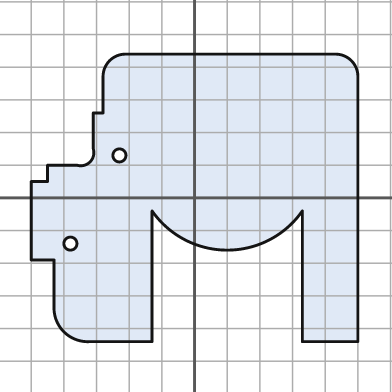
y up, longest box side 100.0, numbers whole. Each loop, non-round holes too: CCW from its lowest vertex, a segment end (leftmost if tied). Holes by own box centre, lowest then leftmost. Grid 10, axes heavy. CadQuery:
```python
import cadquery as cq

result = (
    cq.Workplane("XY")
    .moveTo(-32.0, -44.0)
    .lineTo(-13.0, -44.0)
    .lineTo(-13.0, -4.0)
    .threePointArc((10.0, -16.0), (33.0, -4.0))
    .lineTo(33.0, -44.0)
    .lineTo(50.0, -44.0)
    .lineTo(50.0, 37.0)
    .threePointArc((48.0, 42.0), (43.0, 44.0))
    .lineTo(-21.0, 44.0)
    .threePointArc((-26.0, 42.0), (-28.0, 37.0))
    .lineTo(-28.0, 26.0)
    .lineTo(-31.0, 26.0)
    .lineTo(-31.0, 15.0)
    .threePointArc((-32.0, 11.0), (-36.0, 10.0))
    .lineTo(-45.0, 10.0)
    .lineTo(-45.0, 5.0)
    .lineTo(-50.0, 5.0)
    .lineTo(-50.0, -19.0)
    .lineTo(-43.0, -19.0)
    .lineTo(-43.0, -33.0)
    .threePointArc((-40.0, -41.0), (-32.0, -44.0))
    .close()
    .moveTo(-38.0, -14.0)
    .circle(2.0)
    .moveTo(-23.0, 13.0)
    .circle(2.0)
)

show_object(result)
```